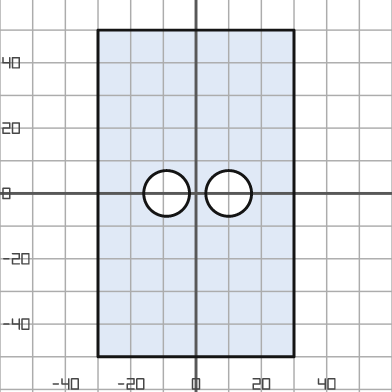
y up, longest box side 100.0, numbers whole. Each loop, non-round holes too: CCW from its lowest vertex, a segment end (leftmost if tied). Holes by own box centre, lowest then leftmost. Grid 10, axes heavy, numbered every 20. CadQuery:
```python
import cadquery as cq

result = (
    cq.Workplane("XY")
    .moveTo(-30.0, -50.0)
    .lineTo(30.0, -50.0)
    .lineTo(30.0, 50.0)
    .lineTo(-30.0, 50.0)
    .close()
    .moveTo(-9.0, 0.0)
    .circle(7.0)
    .moveTo(10.0, 0.0)
    .circle(7.0)
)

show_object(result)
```